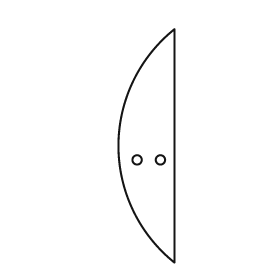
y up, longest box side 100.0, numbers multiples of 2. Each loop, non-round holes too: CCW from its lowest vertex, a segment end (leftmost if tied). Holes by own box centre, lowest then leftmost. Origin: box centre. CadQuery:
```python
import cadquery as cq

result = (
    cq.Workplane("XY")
    .moveTo(12.0, -50.0)
    .lineTo(12.0, 50.0)
    .threePointArc((-12.0, 0.0), (12.0, -50.0))
    .close()
    .moveTo(-4.0, -6.0)
    .circle(2.0)
    .moveTo(6.0, -6.0)
    .circle(2.0)
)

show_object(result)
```